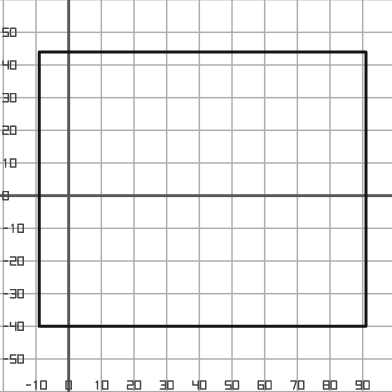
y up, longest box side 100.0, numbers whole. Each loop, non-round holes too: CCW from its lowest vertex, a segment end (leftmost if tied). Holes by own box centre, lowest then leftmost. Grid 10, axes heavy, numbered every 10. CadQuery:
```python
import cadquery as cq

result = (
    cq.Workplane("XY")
    .moveTo(-9.0, -40.0)
    .lineTo(91.0, -40.0)
    .lineTo(91.0, 44.0)
    .lineTo(-9.0, 44.0)
    .close()
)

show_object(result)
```